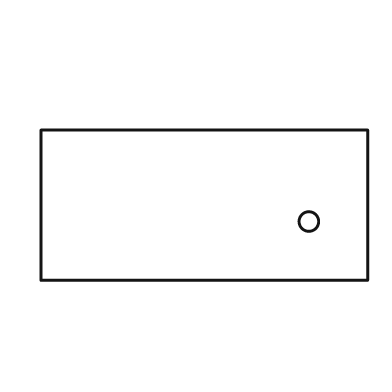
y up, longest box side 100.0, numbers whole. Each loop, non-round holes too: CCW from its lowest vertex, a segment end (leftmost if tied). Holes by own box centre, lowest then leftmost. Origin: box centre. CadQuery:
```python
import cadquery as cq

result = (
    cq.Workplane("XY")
    .moveTo(-50.0, -23.0)
    .lineTo(50.0, -23.0)
    .lineTo(50.0, 23.0)
    .lineTo(-50.0, 23.0)
    .close()
    .moveTo(32.0, -5.0)
    .circle(3.0)
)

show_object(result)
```